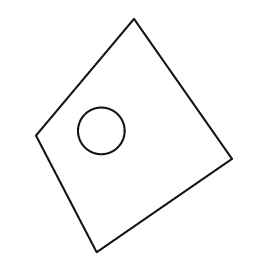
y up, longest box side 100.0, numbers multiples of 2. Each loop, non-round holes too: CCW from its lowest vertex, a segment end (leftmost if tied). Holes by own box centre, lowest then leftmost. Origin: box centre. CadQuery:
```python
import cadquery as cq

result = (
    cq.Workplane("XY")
    .moveTo(-16.0, -50.0)
    .lineTo(42.0, -10.0)
    .lineTo(0.0, 50.0)
    .lineTo(-42.0, 0.0)
    .close()
    .moveTo(-14.0, 2.0)
    .circle(10.0)
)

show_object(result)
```